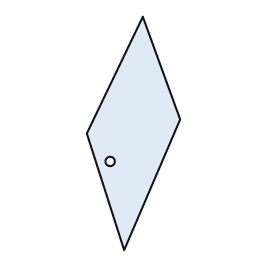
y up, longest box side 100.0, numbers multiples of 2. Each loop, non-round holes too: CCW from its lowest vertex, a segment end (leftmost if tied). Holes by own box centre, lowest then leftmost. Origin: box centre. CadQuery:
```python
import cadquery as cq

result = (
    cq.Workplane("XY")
    .moveTo(-4.0, -50.0)
    .lineTo(20.0, 6.0)
    .lineTo(4.0, 50.0)
    .lineTo(-20.0, 0.0)
    .close()
    .moveTo(-10.0, -12.0)
    .circle(2.0)
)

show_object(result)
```